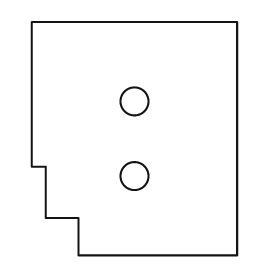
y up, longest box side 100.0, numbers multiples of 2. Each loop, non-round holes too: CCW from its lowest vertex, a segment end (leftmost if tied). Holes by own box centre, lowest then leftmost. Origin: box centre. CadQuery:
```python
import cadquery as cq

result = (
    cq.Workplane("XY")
    .moveTo(-24.0, -50.0)
    .lineTo(44.0, -50.0)
    .lineTo(44.0, 50.0)
    .lineTo(-44.0, 50.0)
    .lineTo(-44.0, -12.0)
    .lineTo(-38.0, -12.0)
    .lineTo(-38.0, -34.0)
    .lineTo(-24.0, -34.0)
    .close()
    .moveTo(0.0, -16.0)
    .circle(6.0)
    .moveTo(0.0, 16.0)
    .circle(6.0)
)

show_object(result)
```